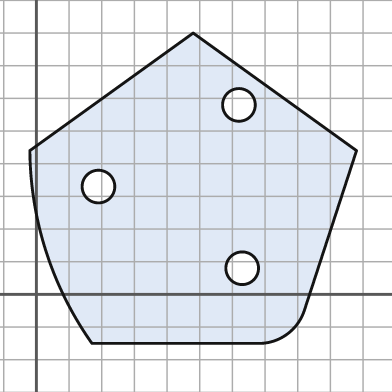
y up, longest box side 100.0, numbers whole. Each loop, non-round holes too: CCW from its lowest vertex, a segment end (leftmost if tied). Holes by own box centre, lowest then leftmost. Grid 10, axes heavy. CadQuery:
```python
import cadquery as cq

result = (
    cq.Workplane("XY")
    .moveTo(17.0, -15.0)
    .lineTo(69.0, -15.0)
    .threePointArc((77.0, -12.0), (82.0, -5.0))
    .lineTo(98.0, 44.0)
    .lineTo(48.0, 80.0)
    .lineTo(-2.0, 44.0)
    .threePointArc((3.0, 13.0), (17.0, -15.0))
    .close()
    .moveTo(63.0, 8.0)
    .circle(5.0)
    .moveTo(19.0, 33.0)
    .circle(5.0)
    .moveTo(62.0, 58.0)
    .circle(5.0)
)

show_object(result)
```